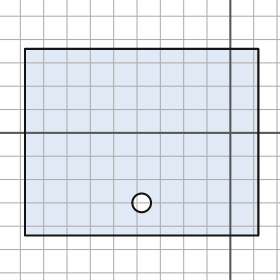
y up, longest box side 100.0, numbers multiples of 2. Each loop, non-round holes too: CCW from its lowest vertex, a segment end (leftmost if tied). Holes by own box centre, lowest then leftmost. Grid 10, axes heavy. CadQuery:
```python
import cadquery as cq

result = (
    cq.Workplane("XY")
    .moveTo(-88.0, -44.0)
    .lineTo(12.0, -44.0)
    .lineTo(12.0, 36.0)
    .lineTo(-88.0, 36.0)
    .close()
    .moveTo(-38.0, -30.0)
    .circle(4.0)
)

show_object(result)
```